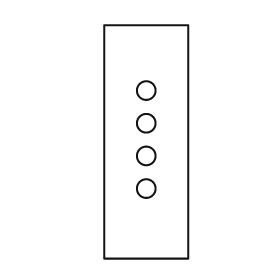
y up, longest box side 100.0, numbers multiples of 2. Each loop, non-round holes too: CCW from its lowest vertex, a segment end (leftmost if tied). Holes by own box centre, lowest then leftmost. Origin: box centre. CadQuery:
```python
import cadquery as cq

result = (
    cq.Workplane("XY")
    .moveTo(-18.0, -50.0)
    .lineTo(18.0, -50.0)
    .lineTo(18.0, 50.0)
    .lineTo(-18.0, 50.0)
    .close()
    .moveTo(0.0, -20.0)
    .circle(4.0)
    .moveTo(0.0, -6.0)
    .circle(4.0)
    .moveTo(0.0, 8.0)
    .circle(4.0)
    .moveTo(0.0, 22.0)
    .circle(4.0)
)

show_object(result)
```